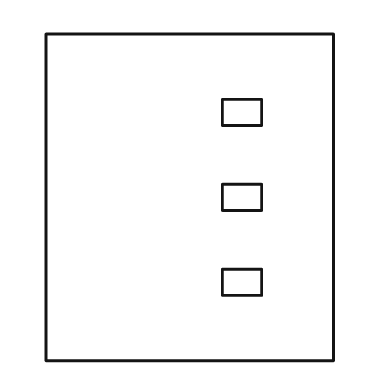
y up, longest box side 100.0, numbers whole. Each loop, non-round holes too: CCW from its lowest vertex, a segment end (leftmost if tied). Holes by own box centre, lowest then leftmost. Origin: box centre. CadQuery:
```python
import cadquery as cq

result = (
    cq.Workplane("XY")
    .moveTo(-44.0, -50.0)
    .lineTo(44.0, -50.0)
    .lineTo(44.0, 50.0)
    .lineTo(-44.0, 50.0)
    .close()
    .moveTo(10.0, -30.0)
    .lineTo(22.0, -30.0)
    .lineTo(22.0, -22.0)
    .lineTo(10.0, -22.0)
    .close()
    .moveTo(10.0, -4.0)
    .lineTo(22.0, -4.0)
    .lineTo(22.0, 4.0)
    .lineTo(10.0, 4.0)
    .close()
    .moveTo(10.0, 22.0)
    .lineTo(22.0, 22.0)
    .lineTo(22.0, 30.0)
    .lineTo(10.0, 30.0)
    .close()
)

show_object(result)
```